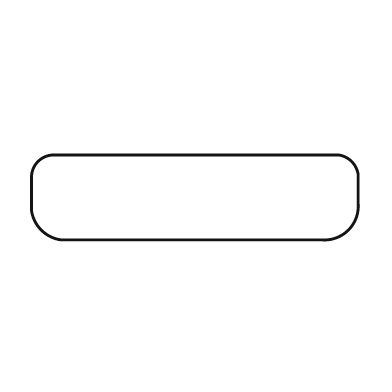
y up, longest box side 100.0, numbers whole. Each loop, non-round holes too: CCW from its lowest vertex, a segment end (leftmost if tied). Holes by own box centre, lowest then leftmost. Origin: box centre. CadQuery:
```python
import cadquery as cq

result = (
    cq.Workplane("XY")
    .moveTo(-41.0, -13.0)
    .lineTo(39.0, -13.0)
    .threePointArc((47.0, -10.0), (50.0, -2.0))
    .lineTo(50.0, 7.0)
    .threePointArc((48.0, 11.0), (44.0, 13.0))
    .lineTo(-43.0, 13.0)
    .threePointArc((-48.0, 11.0), (-50.0, 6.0))
    .lineTo(-50.0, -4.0)
    .threePointArc((-47.0, -10.0), (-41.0, -13.0))
    .close()
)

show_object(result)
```